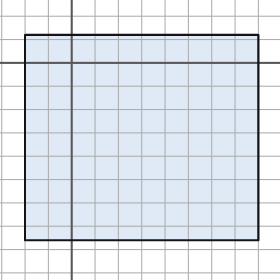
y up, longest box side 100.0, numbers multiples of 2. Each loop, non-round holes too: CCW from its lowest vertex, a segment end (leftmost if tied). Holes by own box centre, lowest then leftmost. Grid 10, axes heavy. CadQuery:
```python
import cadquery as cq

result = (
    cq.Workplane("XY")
    .moveTo(-20.0, -76.0)
    .lineTo(80.0, -76.0)
    .lineTo(80.0, 12.0)
    .lineTo(-20.0, 12.0)
    .close()
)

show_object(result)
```